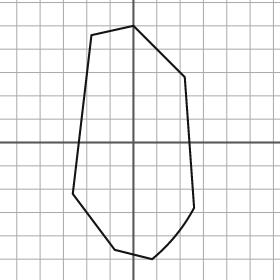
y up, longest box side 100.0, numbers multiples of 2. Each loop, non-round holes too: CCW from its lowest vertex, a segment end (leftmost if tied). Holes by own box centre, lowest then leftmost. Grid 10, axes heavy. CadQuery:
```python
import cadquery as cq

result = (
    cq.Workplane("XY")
    .moveTo(8.0, -50.0)
    .threePointArc((18.0, -40.0), (26.0, -28.0))
    .lineTo(22.0, 28.0)
    .lineTo(0.0, 50.0)
    .lineTo(-18.0, 46.0)
    .lineTo(-26.0, -22.0)
    .lineTo(-8.0, -46.0)
    .close()
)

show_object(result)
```